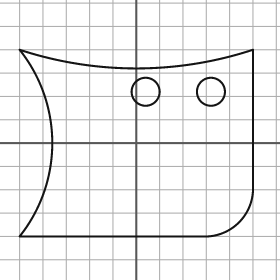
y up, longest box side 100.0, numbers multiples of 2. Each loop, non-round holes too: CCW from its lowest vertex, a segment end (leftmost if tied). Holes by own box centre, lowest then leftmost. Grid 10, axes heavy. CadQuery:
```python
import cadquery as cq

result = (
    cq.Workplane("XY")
    .moveTo(-50.0, -40.0)
    .lineTo(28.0, -40.0)
    .threePointArc((44.0, -34.0), (50.0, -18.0))
    .lineTo(50.0, 40.0)
    .threePointArc((0.0, 32.0), (-50.0, 40.0))
    .threePointArc((-36.0, 0.0), (-50.0, -40.0))
    .close()
    .moveTo(4.0, 22.0)
    .circle(6.0)
    .moveTo(32.0, 22.0)
    .circle(6.0)
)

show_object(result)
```